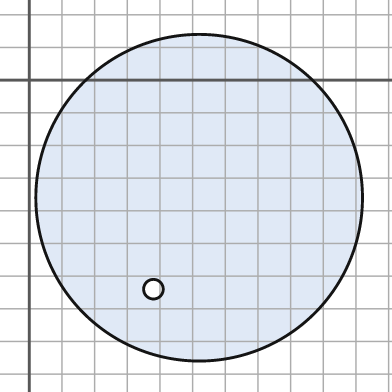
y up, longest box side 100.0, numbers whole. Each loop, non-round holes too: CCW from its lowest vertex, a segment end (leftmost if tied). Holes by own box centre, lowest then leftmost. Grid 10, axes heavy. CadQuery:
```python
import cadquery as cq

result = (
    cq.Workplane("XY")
    .moveTo(52.0, -36.0)
    .circle(50.0)
    .moveTo(38.0, -64.0)
    .circle(3.0)
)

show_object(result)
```